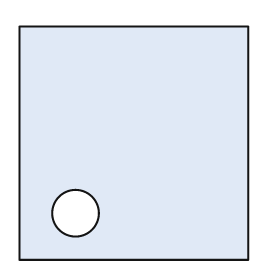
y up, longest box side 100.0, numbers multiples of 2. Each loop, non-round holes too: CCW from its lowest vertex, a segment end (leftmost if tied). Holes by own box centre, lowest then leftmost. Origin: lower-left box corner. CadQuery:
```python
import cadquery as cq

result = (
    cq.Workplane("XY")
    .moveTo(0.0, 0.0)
    .lineTo(98.0, 0.0)
    .lineTo(98.0, 100.0)
    .lineTo(0.0, 100.0)
    .close()
    .moveTo(24.0, 20.0)
    .circle(10.0)
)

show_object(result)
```